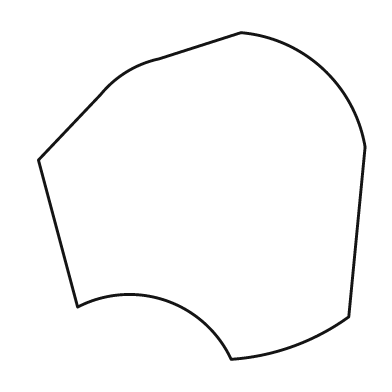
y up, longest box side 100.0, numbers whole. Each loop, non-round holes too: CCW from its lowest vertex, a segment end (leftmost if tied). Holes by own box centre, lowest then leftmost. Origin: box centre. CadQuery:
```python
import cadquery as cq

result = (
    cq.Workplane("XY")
    .moveTo(9.0, -50.0)
    .threePointArc((28.0, -46.0), (45.0, -37.0))
    .lineTo(50.0, 15.0)
    .threePointArc((37.0, 39.0), (12.0, 50.0))
    .lineTo(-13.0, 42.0)
    .threePointArc((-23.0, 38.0), (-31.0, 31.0))
    .lineTo(-50.0, 11.0)
    .lineTo(-38.0, -34.0)
    .threePointArc((-11.0, -32.0), (9.0, -50.0))
    .close()
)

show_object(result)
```